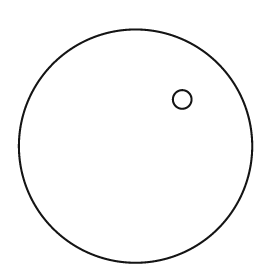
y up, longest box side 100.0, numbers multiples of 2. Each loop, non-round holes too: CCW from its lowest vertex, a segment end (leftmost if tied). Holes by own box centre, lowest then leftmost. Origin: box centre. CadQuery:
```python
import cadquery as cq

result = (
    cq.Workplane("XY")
    .moveTo(0.0, 0.0)
    .circle(50.0)
    .moveTo(20.0, 20.0)
    .circle(4.0)
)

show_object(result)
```